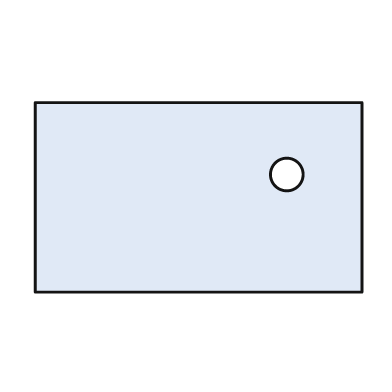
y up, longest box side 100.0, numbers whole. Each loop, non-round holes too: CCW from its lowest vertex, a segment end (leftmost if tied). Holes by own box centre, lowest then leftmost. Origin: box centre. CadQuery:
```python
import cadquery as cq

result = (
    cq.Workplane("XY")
    .moveTo(-50.0, -29.0)
    .lineTo(50.0, -29.0)
    .lineTo(50.0, 29.0)
    .lineTo(-50.0, 29.0)
    .close()
    .moveTo(27.0, 7.0)
    .circle(5.0)
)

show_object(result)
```